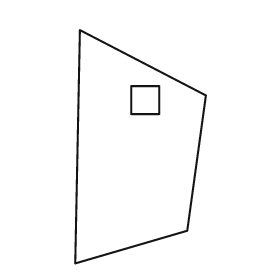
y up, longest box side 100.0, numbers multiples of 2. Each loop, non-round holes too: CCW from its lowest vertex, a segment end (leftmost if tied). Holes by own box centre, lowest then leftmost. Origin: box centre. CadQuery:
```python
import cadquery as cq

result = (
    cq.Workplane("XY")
    .moveTo(-28.0, -50.0)
    .lineTo(20.0, -36.0)
    .lineTo(28.0, 22.0)
    .lineTo(-26.0, 50.0)
    .close()
    .moveTo(-4.0, 14.0)
    .lineTo(8.0, 14.0)
    .lineTo(8.0, 26.0)
    .lineTo(-4.0, 26.0)
    .close()
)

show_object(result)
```